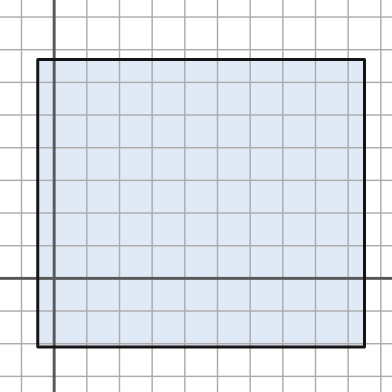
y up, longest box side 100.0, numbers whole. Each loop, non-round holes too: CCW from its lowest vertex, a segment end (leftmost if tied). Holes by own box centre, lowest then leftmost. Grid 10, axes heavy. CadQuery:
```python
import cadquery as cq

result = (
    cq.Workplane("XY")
    .moveTo(-5.0, -21.0)
    .lineTo(95.0, -21.0)
    .lineTo(95.0, 67.0)
    .lineTo(-5.0, 67.0)
    .close()
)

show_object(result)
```